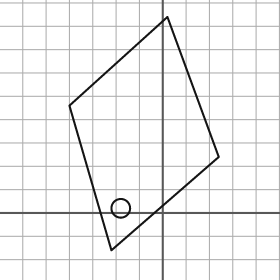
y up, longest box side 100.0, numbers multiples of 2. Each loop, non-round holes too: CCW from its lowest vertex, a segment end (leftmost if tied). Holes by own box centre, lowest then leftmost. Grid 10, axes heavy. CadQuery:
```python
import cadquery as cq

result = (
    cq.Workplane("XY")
    .moveTo(-22.0, -16.0)
    .lineTo(24.0, 24.0)
    .lineTo(2.0, 84.0)
    .lineTo(-40.0, 46.0)
    .close()
    .moveTo(-18.0, 2.0)
    .circle(4.0)
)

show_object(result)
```